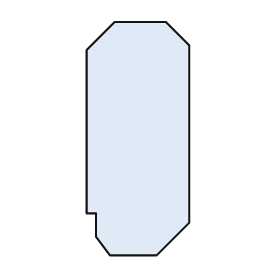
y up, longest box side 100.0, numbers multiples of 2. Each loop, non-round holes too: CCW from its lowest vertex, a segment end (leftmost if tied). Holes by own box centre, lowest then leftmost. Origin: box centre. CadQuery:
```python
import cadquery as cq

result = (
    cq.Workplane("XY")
    .moveTo(-12.0, -50.0)
    .lineTo(8.0, -50.0)
    .lineTo(22.0, -36.0)
    .lineTo(22.0, 40.0)
    .lineTo(12.0, 50.0)
    .lineTo(-10.0, 50.0)
    .lineTo(-22.0, 38.0)
    .lineTo(-22.0, -32.0)
    .lineTo(-18.0, -32.0)
    .lineTo(-18.0, -42.0)
    .close()
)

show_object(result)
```